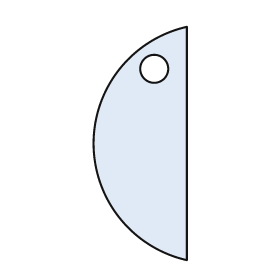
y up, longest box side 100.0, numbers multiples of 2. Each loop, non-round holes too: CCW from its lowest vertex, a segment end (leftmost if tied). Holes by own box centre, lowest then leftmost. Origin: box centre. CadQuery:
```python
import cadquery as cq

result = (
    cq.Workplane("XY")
    .moveTo(20.0, -50.0)
    .lineTo(20.0, 50.0)
    .threePointArc((-20.0, 0.0), (20.0, -50.0))
    .close()
    .moveTo(6.0, 32.0)
    .circle(6.0)
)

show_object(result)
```